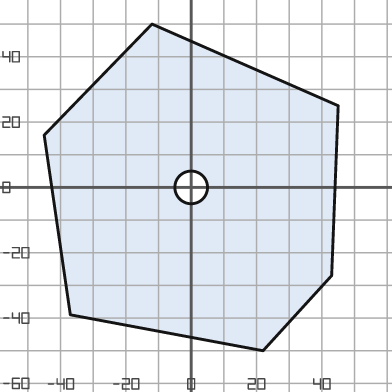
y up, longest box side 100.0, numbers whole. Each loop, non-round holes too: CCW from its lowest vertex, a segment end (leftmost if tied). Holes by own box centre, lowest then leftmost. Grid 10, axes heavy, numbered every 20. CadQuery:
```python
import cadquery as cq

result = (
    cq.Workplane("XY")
    .moveTo(22.0, -50.0)
    .lineTo(43.0, -27.0)
    .lineTo(45.0, 25.0)
    .lineTo(-12.0, 50.0)
    .lineTo(-45.0, 16.0)
    .lineTo(-37.0, -39.0)
    .close()
    .moveTo(0.0, 0.0)
    .circle(5.0)
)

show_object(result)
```